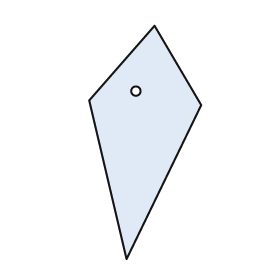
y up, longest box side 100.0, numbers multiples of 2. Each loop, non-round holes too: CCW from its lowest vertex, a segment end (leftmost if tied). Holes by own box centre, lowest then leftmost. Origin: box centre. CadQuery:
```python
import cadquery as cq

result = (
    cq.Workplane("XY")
    .moveTo(-8.0, -50.0)
    .lineTo(24.0, 16.0)
    .lineTo(4.0, 50.0)
    .lineTo(-24.0, 18.0)
    .close()
    .moveTo(-4.0, 22.0)
    .circle(2.0)
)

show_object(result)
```